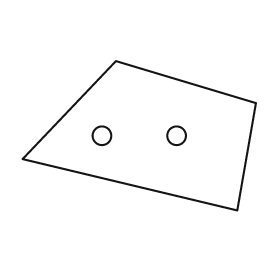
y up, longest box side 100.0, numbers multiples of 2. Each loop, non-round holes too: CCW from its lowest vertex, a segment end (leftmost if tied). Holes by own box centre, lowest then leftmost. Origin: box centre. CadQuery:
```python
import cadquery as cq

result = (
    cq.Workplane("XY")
    .moveTo(42.0, -32.0)
    .lineTo(50.0, 14.0)
    .lineTo(-10.0, 32.0)
    .lineTo(-50.0, -10.0)
    .close()
    .moveTo(-16.0, 0.0)
    .circle(4.0)
    .moveTo(16.0, 0.0)
    .circle(4.0)
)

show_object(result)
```